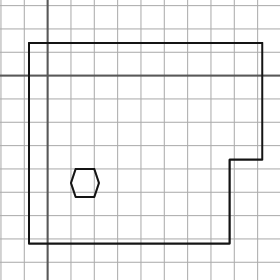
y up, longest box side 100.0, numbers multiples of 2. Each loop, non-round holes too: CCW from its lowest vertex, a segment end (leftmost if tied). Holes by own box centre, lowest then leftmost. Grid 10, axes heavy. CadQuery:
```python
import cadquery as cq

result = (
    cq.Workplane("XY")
    .moveTo(-8.0, -72.0)
    .lineTo(78.0, -72.0)
    .lineTo(78.0, -36.0)
    .lineTo(92.0, -36.0)
    .lineTo(92.0, 14.0)
    .lineTo(-8.0, 14.0)
    .close()
    .moveTo(12.0, -52.0)
    .lineTo(20.0, -52.0)
    .lineTo(22.0, -46.0)
    .lineTo(20.0, -40.0)
    .lineTo(12.0, -40.0)
    .lineTo(10.0, -46.0)
    .close()
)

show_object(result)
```